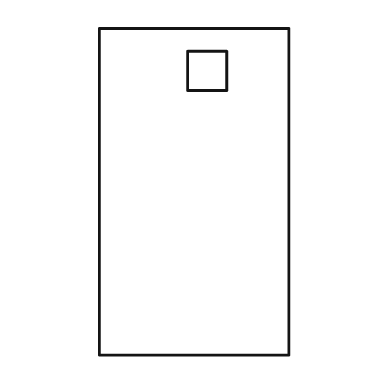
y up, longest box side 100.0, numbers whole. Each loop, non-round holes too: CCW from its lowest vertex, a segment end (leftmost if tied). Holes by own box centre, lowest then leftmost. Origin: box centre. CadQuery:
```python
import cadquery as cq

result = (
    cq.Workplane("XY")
    .moveTo(-29.0, -50.0)
    .lineTo(29.0, -50.0)
    .lineTo(29.0, 50.0)
    .lineTo(-29.0, 50.0)
    .close()
    .moveTo(-2.0, 31.0)
    .lineTo(10.0, 31.0)
    .lineTo(10.0, 43.0)
    .lineTo(-2.0, 43.0)
    .close()
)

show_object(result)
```